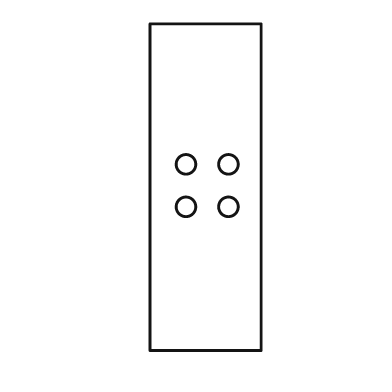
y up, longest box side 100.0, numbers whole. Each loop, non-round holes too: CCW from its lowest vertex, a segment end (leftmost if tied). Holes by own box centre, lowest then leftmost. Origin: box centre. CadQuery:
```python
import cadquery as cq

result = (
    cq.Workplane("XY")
    .moveTo(-17.0, -50.0)
    .lineTo(17.0, -50.0)
    .lineTo(17.0, 50.0)
    .lineTo(-17.0, 50.0)
    .close()
    .moveTo(-6.0, -6.0)
    .circle(3.0)
    .moveTo(7.0, -6.0)
    .circle(3.0)
    .moveTo(-6.0, 7.0)
    .circle(3.0)
    .moveTo(7.0, 7.0)
    .circle(3.0)
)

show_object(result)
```